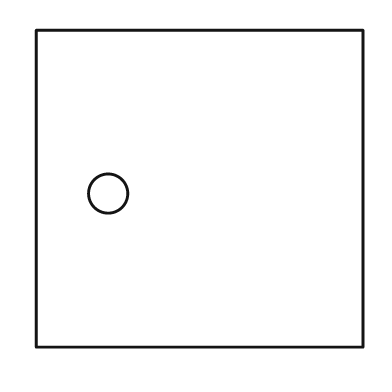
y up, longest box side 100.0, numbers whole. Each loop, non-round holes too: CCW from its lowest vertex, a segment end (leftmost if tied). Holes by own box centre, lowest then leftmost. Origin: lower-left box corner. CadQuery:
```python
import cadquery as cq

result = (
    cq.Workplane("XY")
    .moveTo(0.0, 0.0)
    .lineTo(100.0, 0.0)
    .lineTo(100.0, 97.0)
    .lineTo(0.0, 97.0)
    .close()
    .moveTo(22.0, 47.0)
    .circle(6.0)
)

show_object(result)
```